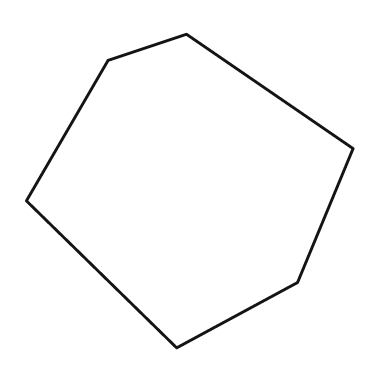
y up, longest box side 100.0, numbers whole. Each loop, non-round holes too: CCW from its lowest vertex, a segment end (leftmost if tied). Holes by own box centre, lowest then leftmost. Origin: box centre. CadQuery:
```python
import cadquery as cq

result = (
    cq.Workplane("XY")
    .moveTo(-4.0, -48.0)
    .lineTo(33.0, -28.0)
    .lineTo(50.0, 13.0)
    .lineTo(-1.0, 48.0)
    .lineTo(-25.0, 40.0)
    .lineTo(-50.0, -3.0)
    .close()
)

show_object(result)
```